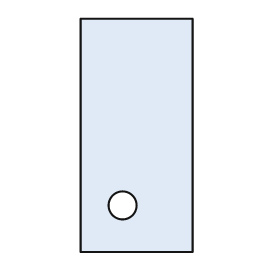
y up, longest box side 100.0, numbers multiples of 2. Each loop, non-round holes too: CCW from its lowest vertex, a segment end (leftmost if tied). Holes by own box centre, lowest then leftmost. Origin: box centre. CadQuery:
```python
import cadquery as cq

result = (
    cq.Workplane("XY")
    .moveTo(-24.0, -50.0)
    .lineTo(24.0, -50.0)
    .lineTo(24.0, 50.0)
    .lineTo(-24.0, 50.0)
    .close()
    .moveTo(-6.0, -30.0)
    .circle(6.0)
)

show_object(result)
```